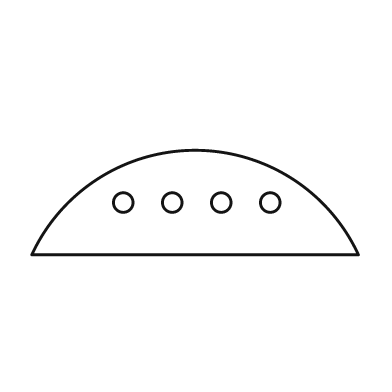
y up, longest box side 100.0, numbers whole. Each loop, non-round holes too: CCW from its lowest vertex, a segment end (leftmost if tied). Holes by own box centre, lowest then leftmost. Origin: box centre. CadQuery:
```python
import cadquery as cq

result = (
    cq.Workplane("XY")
    .moveTo(-50.0, -16.0)
    .lineTo(50.0, -16.0)
    .threePointArc((0.0, 16.0), (-50.0, -16.0))
    .close()
    .moveTo(-22.0, 0.0)
    .circle(3.0)
    .moveTo(-7.0, 0.0)
    .circle(3.0)
    .moveTo(8.0, 0.0)
    .circle(3.0)
    .moveTo(23.0, 0.0)
    .circle(3.0)
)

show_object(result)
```